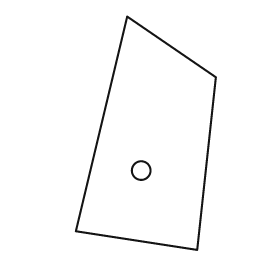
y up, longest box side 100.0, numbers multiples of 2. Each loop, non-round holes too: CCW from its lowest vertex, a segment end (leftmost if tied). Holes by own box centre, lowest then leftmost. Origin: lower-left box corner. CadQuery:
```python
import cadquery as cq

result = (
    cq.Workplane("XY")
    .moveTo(52.0, 0.0)
    .lineTo(60.0, 74.0)
    .lineTo(22.0, 100.0)
    .lineTo(0.0, 8.0)
    .close()
    .moveTo(28.0, 34.0)
    .circle(4.0)
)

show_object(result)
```